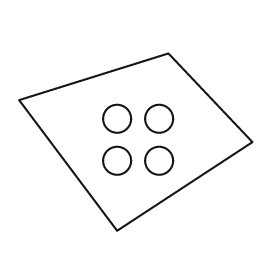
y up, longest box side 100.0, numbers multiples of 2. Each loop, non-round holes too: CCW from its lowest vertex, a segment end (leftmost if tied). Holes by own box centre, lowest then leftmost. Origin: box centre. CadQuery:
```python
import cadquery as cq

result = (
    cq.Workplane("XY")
    .moveTo(-8.0, -38.0)
    .lineTo(50.0, 0.0)
    .lineTo(14.0, 38.0)
    .lineTo(-50.0, 18.0)
    .close()
    .moveTo(-8.0, -8.0)
    .circle(6.0)
    .moveTo(10.0, -8.0)
    .circle(6.0)
    .moveTo(-8.0, 10.0)
    .circle(6.0)
    .moveTo(10.0, 10.0)
    .circle(6.0)
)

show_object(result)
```